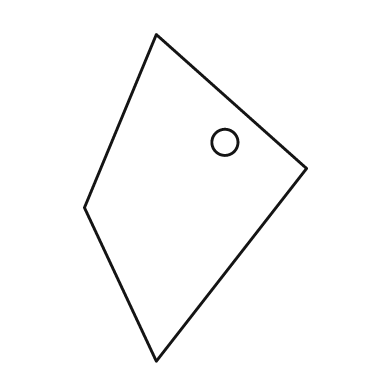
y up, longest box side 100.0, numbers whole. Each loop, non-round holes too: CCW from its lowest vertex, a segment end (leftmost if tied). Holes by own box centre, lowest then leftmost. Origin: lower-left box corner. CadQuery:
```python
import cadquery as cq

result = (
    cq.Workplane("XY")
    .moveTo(22.0, 0.0)
    .lineTo(68.0, 59.0)
    .lineTo(22.0, 100.0)
    .lineTo(0.0, 47.0)
    .close()
    .moveTo(43.0, 67.0)
    .circle(4.0)
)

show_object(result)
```